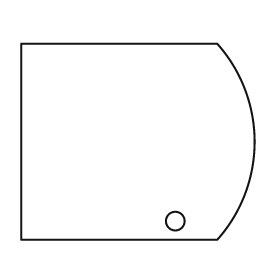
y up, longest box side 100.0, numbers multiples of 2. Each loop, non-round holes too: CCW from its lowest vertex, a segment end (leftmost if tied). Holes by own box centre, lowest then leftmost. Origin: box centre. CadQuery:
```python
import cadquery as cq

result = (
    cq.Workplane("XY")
    .moveTo(-50.0, -42.0)
    .lineTo(34.0, -42.0)
    .threePointArc((50.0, 0.0), (34.0, 42.0))
    .lineTo(-50.0, 42.0)
    .close()
    .moveTo(16.0, -34.0)
    .circle(4.0)
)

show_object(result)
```